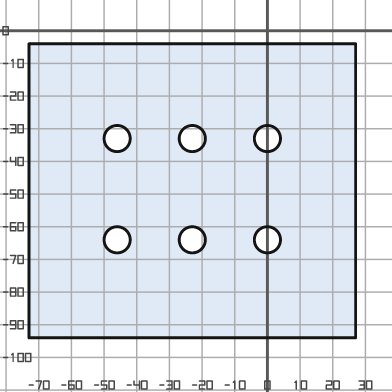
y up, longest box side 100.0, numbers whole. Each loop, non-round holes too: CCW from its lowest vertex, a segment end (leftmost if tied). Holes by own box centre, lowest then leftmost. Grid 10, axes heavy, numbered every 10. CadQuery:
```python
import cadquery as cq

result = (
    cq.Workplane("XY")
    .moveTo(-73.0, -94.0)
    .lineTo(27.0, -94.0)
    .lineTo(27.0, -4.0)
    .lineTo(-73.0, -4.0)
    .close()
    .moveTo(-46.0, -64.0)
    .circle(4.0)
    .moveTo(-23.0, -64.0)
    .circle(4.0)
    .moveTo(0.0, -64.0)
    .circle(4.0)
    .moveTo(-46.0, -33.0)
    .circle(4.0)
    .moveTo(-23.0, -33.0)
    .circle(4.0)
    .moveTo(0.0, -33.0)
    .circle(4.0)
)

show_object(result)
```